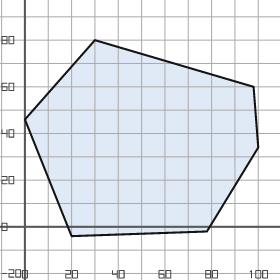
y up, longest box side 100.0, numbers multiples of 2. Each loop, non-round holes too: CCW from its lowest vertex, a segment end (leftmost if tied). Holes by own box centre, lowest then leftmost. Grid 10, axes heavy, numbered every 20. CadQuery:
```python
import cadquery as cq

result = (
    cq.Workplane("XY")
    .moveTo(20.0, -4.0)
    .lineTo(78.0, -2.0)
    .lineTo(100.0, 34.0)
    .lineTo(98.0, 60.0)
    .lineTo(30.0, 80.0)
    .lineTo(0.0, 46.0)
    .close()
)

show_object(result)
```